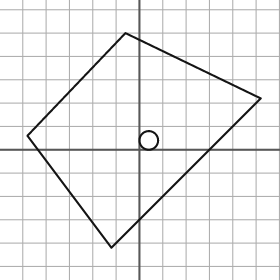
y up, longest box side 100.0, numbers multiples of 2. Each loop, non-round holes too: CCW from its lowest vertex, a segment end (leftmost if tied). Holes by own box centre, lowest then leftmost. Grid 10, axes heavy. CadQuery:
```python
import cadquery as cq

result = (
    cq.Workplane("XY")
    .moveTo(-12.0, -42.0)
    .lineTo(52.0, 22.0)
    .lineTo(-6.0, 50.0)
    .lineTo(-48.0, 6.0)
    .close()
    .moveTo(4.0, 4.0)
    .circle(4.0)
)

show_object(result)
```